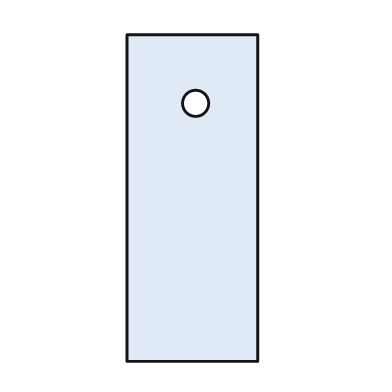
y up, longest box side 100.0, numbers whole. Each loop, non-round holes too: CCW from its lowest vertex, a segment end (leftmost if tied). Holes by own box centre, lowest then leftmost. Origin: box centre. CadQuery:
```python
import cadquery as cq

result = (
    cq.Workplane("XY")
    .moveTo(-20.0, -50.0)
    .lineTo(20.0, -50.0)
    .lineTo(20.0, 50.0)
    .lineTo(-20.0, 50.0)
    .close()
    .moveTo(1.0, 29.0)
    .circle(4.0)
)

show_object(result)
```